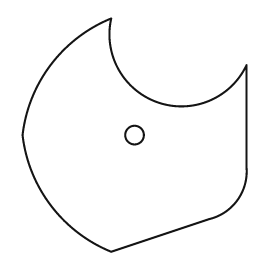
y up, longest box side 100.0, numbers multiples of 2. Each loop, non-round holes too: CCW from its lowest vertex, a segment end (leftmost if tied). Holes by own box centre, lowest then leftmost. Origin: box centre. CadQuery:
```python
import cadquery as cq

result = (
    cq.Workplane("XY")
    .moveTo(-10.0, -50.0)
    .lineTo(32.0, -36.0)
    .threePointArc((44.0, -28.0), (48.0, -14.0))
    .lineTo(48.0, 30.0)
    .threePointArc((10.0, 14.0), (-10.0, 50.0))
    .threePointArc((-36.0, 30.0), (-48.0, 0.0))
    .threePointArc((-36.0, -30.0), (-10.0, -50.0))
    .close()
    .moveTo(0.0, 0.0)
    .circle(4.0)
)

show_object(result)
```